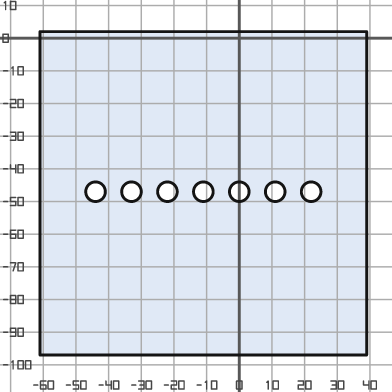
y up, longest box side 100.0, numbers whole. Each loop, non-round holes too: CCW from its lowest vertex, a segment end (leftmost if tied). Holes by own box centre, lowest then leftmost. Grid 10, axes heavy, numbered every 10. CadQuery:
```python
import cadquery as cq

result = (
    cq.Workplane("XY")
    .moveTo(-61.0, -97.0)
    .lineTo(39.0, -97.0)
    .lineTo(39.0, 2.0)
    .lineTo(-61.0, 2.0)
    .close()
    .moveTo(-44.0, -47.0)
    .circle(3.0)
    .moveTo(-33.0, -47.0)
    .circle(3.0)
    .moveTo(-22.0, -47.0)
    .circle(3.0)
    .moveTo(-11.0, -47.0)
    .circle(3.0)
    .moveTo(0.0, -47.0)
    .circle(3.0)
    .moveTo(11.0, -47.0)
    .circle(3.0)
    .moveTo(22.0, -47.0)
    .circle(3.0)
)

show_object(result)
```